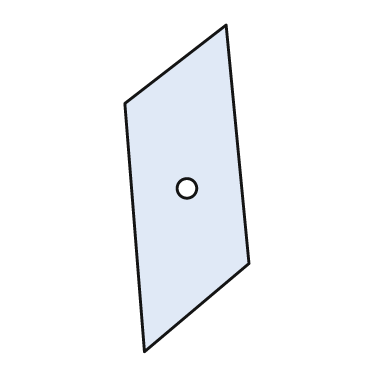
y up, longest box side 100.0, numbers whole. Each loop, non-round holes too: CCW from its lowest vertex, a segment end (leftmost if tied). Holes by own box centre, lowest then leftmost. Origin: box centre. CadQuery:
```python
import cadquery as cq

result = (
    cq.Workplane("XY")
    .moveTo(-13.0, -50.0)
    .lineTo(19.0, -23.0)
    .lineTo(12.0, 50.0)
    .lineTo(-19.0, 26.0)
    .close()
    .moveTo(0.0, 0.0)
    .circle(3.0)
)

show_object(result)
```